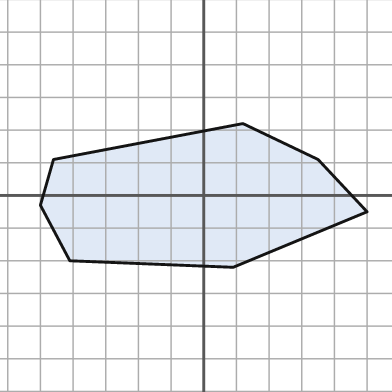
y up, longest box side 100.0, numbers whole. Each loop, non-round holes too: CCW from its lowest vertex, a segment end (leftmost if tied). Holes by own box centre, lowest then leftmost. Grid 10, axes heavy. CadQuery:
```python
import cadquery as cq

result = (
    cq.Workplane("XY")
    .moveTo(9.0, -22.0)
    .lineTo(50.0, -5.0)
    .lineTo(35.0, 11.0)
    .lineTo(12.0, 22.0)
    .lineTo(-46.0, 11.0)
    .lineTo(-50.0, -3.0)
    .lineTo(-41.0, -20.0)
    .close()
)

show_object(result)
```